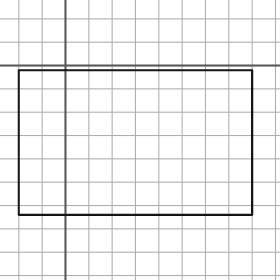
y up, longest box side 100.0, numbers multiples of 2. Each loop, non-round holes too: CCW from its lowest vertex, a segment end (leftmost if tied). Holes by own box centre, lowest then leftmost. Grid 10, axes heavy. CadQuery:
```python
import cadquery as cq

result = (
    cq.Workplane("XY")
    .moveTo(-20.0, -64.0)
    .lineTo(80.0, -64.0)
    .lineTo(80.0, -2.0)
    .lineTo(-20.0, -2.0)
    .close()
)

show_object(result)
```